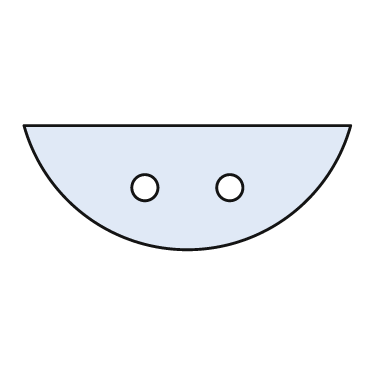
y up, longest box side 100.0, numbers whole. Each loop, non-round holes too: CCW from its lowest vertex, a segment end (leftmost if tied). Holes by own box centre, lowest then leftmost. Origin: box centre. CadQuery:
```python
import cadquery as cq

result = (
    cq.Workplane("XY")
    .moveTo(-50.0, 19.0)
    .threePointArc((0.0, -19.0), (50.0, 19.0))
    .close()
    .moveTo(-13.0, 0.0)
    .circle(4.0)
    .moveTo(13.0, 0.0)
    .circle(4.0)
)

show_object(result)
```